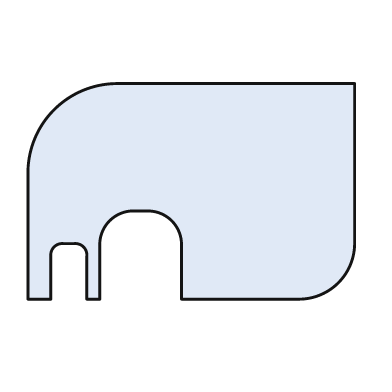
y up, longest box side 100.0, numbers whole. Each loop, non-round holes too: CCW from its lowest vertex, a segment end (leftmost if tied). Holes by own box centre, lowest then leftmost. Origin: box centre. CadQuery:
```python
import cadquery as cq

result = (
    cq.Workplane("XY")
    .moveTo(-50.0, -33.0)
    .lineTo(-43.0, -33.0)
    .lineTo(-43.0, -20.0)
    .threePointArc((-42.0, -17.0), (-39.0, -16.0))
    .lineTo(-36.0, -16.0)
    .threePointArc((-33.0, -17.0), (-32.0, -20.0))
    .lineTo(-32.0, -33.0)
    .lineTo(-28.0, -33.0)
    .lineTo(-28.0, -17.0)
    .threePointArc((-25.0, -9.0), (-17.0, -6.0))
    .lineTo(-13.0, -6.0)
    .threePointArc((-6.0, -9.0), (-3.0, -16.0))
    .lineTo(-3.0, -33.0)
    .lineTo(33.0, -33.0)
    .threePointArc((45.0, -28.0), (50.0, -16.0))
    .lineTo(50.0, 33.0)
    .lineTo(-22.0, 33.0)
    .threePointArc((-42.0, 25.0), (-50.0, 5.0))
    .close()
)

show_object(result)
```